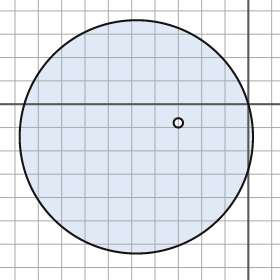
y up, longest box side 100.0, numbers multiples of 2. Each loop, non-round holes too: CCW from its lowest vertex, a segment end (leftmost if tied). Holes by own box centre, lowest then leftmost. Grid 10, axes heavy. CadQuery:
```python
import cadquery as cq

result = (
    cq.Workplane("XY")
    .moveTo(-48.0, -14.0)
    .circle(50.0)
    .moveTo(-30.0, -8.0)
    .circle(2.0)
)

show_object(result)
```